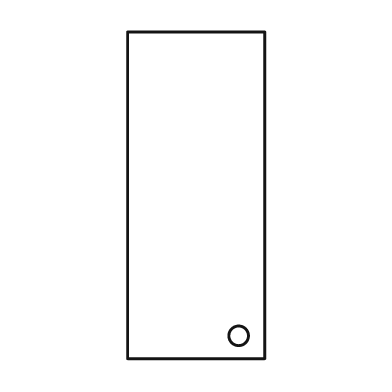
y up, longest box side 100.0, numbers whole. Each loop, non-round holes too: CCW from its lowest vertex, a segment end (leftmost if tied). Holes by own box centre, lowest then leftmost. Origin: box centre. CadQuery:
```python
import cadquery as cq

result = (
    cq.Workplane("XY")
    .moveTo(-21.0, -50.0)
    .lineTo(21.0, -50.0)
    .lineTo(21.0, 50.0)
    .lineTo(-21.0, 50.0)
    .close()
    .moveTo(13.0, -43.0)
    .circle(3.0)
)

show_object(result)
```